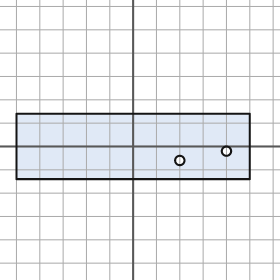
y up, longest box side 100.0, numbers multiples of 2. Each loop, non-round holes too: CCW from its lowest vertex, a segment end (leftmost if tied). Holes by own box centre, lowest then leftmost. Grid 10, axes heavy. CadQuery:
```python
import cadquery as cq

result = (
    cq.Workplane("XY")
    .moveTo(-50.0, -14.0)
    .lineTo(50.0, -14.0)
    .lineTo(50.0, 14.0)
    .lineTo(-50.0, 14.0)
    .close()
    .moveTo(20.0, -6.0)
    .circle(2.0)
    .moveTo(40.0, -2.0)
    .circle(2.0)
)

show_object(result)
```